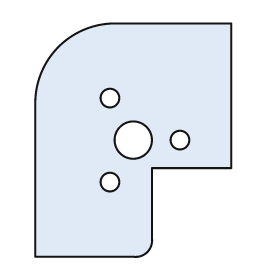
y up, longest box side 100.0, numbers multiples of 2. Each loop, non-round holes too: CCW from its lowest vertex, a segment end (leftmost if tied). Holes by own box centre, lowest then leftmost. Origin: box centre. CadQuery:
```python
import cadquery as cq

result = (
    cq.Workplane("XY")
    .moveTo(-42.0, -50.0)
    .lineTo(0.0, -50.0)
    .threePointArc((6.0, -48.0), (8.0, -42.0))
    .lineTo(8.0, -12.0)
    .lineTo(42.0, -12.0)
    .lineTo(42.0, 50.0)
    .lineTo(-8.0, 50.0)
    .threePointArc((-32.0, 40.0), (-42.0, 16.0))
    .close()
    .moveTo(-10.0, -18.0)
    .circle(4.0)
    .moveTo(0.0, 0.0)
    .circle(8.0)
    .moveTo(20.0, 0.0)
    .circle(4.0)
    .moveTo(-10.0, 18.0)
    .circle(4.0)
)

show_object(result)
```